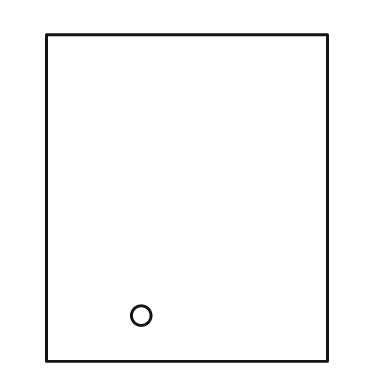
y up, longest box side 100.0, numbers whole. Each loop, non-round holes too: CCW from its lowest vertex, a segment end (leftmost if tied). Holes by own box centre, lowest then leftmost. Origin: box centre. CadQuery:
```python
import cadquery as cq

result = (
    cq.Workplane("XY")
    .moveTo(-43.0, -50.0)
    .lineTo(43.0, -50.0)
    .lineTo(43.0, 50.0)
    .lineTo(-43.0, 50.0)
    .close()
    .moveTo(-14.0, -36.0)
    .circle(3.0)
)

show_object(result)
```